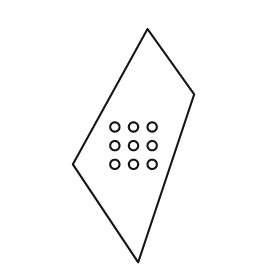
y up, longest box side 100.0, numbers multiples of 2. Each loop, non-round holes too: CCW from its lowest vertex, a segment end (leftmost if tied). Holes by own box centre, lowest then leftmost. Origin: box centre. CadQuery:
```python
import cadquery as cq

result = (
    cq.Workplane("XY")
    .moveTo(2.0, -50.0)
    .lineTo(26.0, 22.0)
    .lineTo(6.0, 50.0)
    .lineTo(-26.0, -8.0)
    .close()
    .moveTo(-8.0, -8.0)
    .circle(2.0)
    .moveTo(0.0, -8.0)
    .circle(2.0)
    .moveTo(8.0, -8.0)
    .circle(2.0)
    .moveTo(-8.0, 0.0)
    .circle(2.0)
    .moveTo(0.0, 0.0)
    .circle(2.0)
    .moveTo(8.0, 0.0)
    .circle(2.0)
    .moveTo(-8.0, 8.0)
    .circle(2.0)
    .moveTo(0.0, 8.0)
    .circle(2.0)
    .moveTo(8.0, 8.0)
    .circle(2.0)
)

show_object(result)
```